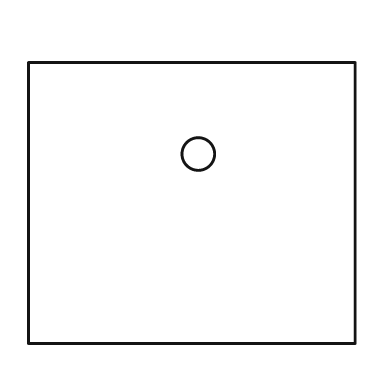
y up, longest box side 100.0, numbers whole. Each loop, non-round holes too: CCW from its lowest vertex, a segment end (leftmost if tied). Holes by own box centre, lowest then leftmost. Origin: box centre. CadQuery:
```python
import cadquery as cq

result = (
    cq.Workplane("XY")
    .moveTo(-50.0, -43.0)
    .lineTo(50.0, -43.0)
    .lineTo(50.0, 43.0)
    .lineTo(-50.0, 43.0)
    .close()
    .moveTo(2.0, 15.0)
    .circle(5.0)
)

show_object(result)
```